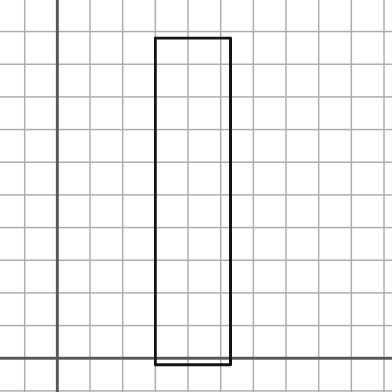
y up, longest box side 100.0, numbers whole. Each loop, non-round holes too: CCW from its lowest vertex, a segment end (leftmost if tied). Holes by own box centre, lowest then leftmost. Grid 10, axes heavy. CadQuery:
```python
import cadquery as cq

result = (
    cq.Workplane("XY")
    .moveTo(30.0, -2.0)
    .lineTo(53.0, -2.0)
    .lineTo(53.0, 98.0)
    .lineTo(30.0, 98.0)
    .close()
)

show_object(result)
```